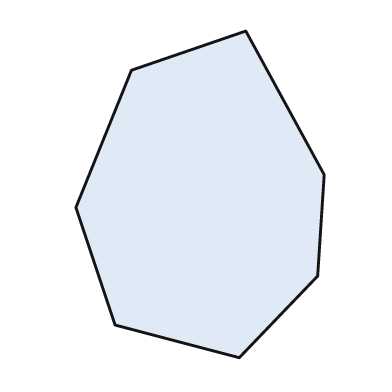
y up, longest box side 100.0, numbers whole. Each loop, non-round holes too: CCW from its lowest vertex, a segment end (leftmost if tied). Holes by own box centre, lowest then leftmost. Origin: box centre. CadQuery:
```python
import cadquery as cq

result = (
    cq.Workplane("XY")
    .moveTo(12.0, -50.0)
    .lineTo(36.0, -25.0)
    .lineTo(38.0, 6.0)
    .lineTo(14.0, 50.0)
    .lineTo(-21.0, 38.0)
    .lineTo(-38.0, -4.0)
    .lineTo(-26.0, -40.0)
    .close()
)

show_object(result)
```